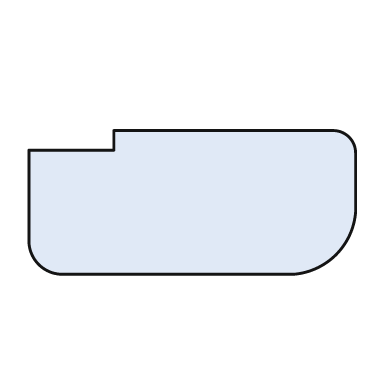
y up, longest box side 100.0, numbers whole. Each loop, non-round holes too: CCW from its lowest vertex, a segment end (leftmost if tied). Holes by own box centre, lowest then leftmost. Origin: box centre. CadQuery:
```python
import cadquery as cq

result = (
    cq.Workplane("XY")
    .moveTo(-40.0, -22.0)
    .lineTo(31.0, -22.0)
    .threePointArc((44.0, -16.0), (50.0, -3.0))
    .lineTo(50.0, 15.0)
    .threePointArc((48.0, 20.0), (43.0, 22.0))
    .lineTo(-24.0, 22.0)
    .lineTo(-24.0, 16.0)
    .lineTo(-50.0, 16.0)
    .lineTo(-50.0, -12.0)
    .threePointArc((-47.0, -19.0), (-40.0, -22.0))
    .close()
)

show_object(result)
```